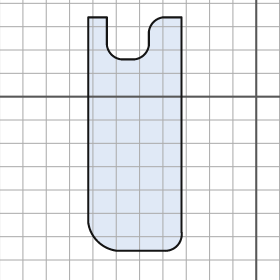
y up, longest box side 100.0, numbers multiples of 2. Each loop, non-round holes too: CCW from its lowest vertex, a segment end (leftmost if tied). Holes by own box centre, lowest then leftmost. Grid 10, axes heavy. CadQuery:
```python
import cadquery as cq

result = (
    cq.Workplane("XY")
    .moveTo(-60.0, -66.0)
    .lineTo(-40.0, -66.0)
    .threePointArc((-34.0, -64.0), (-32.0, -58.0))
    .lineTo(-32.0, 34.0)
    .lineTo(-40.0, 34.0)
    .threePointArc((-44.0, 32.0), (-46.0, 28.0))
    .lineTo(-46.0, 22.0)
    .threePointArc((-48.0, 18.0), (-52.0, 16.0))
    .lineTo(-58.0, 16.0)
    .threePointArc((-62.0, 18.0), (-64.0, 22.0))
    .lineTo(-64.0, 34.0)
    .lineTo(-72.0, 34.0)
    .lineTo(-72.0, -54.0)
    .threePointArc((-68.0, -62.0), (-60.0, -66.0))
    .close()
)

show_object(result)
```